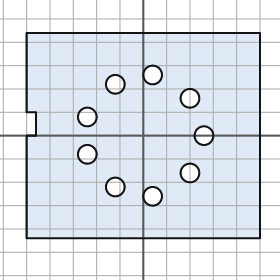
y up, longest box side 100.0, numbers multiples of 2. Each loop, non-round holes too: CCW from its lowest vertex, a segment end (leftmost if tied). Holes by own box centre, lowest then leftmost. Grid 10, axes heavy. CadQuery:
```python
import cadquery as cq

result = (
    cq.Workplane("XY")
    .moveTo(-50.0, -44.0)
    .lineTo(50.0, -44.0)
    .lineTo(50.0, 44.0)
    .lineTo(-50.0, 44.0)
    .lineTo(-50.0, 10.0)
    .lineTo(-46.0, 10.0)
    .lineTo(-46.0, 0.0)
    .lineTo(-50.0, 0.0)
    .close()
    .moveTo(4.0, -26.0)
    .circle(4.0)
    .moveTo(-12.0, -22.0)
    .circle(4.0)
    .moveTo(20.0, -16.0)
    .circle(4.0)
    .moveTo(-24.0, -8.0)
    .circle(4.0)
    .moveTo(26.0, 0.0)
    .circle(4.0)
    .moveTo(-24.0, 8.0)
    .circle(4.0)
    .moveTo(20.0, 16.0)
    .circle(4.0)
    .moveTo(-12.0, 22.0)
    .circle(4.0)
    .moveTo(4.0, 26.0)
    .circle(4.0)
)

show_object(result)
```